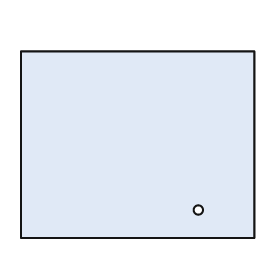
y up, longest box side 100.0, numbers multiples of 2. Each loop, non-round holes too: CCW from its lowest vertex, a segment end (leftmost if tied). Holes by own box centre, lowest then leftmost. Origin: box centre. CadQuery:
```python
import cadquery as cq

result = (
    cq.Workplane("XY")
    .moveTo(-50.0, -40.0)
    .lineTo(50.0, -40.0)
    .lineTo(50.0, 40.0)
    .lineTo(-50.0, 40.0)
    .close()
    .moveTo(26.0, -28.0)
    .circle(2.0)
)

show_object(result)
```